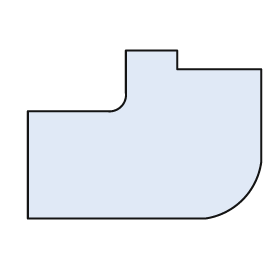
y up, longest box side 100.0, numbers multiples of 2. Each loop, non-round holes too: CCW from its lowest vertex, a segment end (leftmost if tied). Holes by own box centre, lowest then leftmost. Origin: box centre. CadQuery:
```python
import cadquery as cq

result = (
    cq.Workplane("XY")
    .moveTo(-50.0, -36.0)
    .lineTo(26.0, -36.0)
    .threePointArc((42.0, -28.0), (50.0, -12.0))
    .lineTo(50.0, 28.0)
    .lineTo(14.0, 28.0)
    .lineTo(14.0, 36.0)
    .lineTo(-8.0, 36.0)
    .lineTo(-8.0, 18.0)
    .threePointArc((-10.0, 12.0), (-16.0, 10.0))
    .lineTo(-50.0, 10.0)
    .close()
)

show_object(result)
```